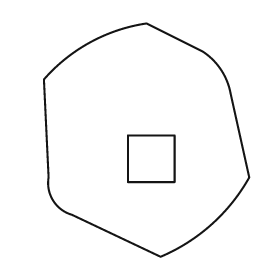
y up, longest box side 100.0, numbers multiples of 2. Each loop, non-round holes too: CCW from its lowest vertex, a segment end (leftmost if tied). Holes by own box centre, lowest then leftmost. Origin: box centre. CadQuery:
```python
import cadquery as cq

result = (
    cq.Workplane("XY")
    .moveTo(6.0, -50.0)
    .threePointArc((28.0, -36.0), (44.0, -16.0))
    .lineTo(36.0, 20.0)
    .threePointArc((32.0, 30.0), (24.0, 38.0))
    .lineTo(0.0, 50.0)
    .threePointArc((-24.0, 42.0), (-44.0, 26.0))
    .lineTo(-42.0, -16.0)
    .threePointArc((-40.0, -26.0), (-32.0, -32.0))
    .close()
    .moveTo(-8.0, -18.0)
    .lineTo(12.0, -18.0)
    .lineTo(12.0, 2.0)
    .lineTo(-8.0, 2.0)
    .close()
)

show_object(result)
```